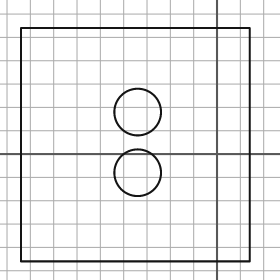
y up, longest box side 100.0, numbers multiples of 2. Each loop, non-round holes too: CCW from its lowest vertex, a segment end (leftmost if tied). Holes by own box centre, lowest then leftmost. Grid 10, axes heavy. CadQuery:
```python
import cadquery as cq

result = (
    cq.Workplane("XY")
    .moveTo(-84.0, -46.0)
    .lineTo(14.0, -46.0)
    .lineTo(14.0, 54.0)
    .lineTo(-84.0, 54.0)
    .close()
    .moveTo(-34.0, -8.0)
    .circle(10.0)
    .moveTo(-34.0, 18.0)
    .circle(10.0)
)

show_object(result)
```